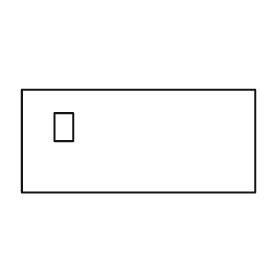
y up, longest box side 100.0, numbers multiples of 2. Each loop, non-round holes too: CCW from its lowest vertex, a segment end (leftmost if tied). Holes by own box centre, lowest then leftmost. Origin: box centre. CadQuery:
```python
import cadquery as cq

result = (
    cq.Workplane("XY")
    .moveTo(-50.0, -22.0)
    .lineTo(50.0, -22.0)
    .lineTo(50.0, 22.0)
    .lineTo(-50.0, 22.0)
    .close()
    .moveTo(-36.0, 0.0)
    .lineTo(-28.0, 0.0)
    .lineTo(-28.0, 12.0)
    .lineTo(-36.0, 12.0)
    .close()
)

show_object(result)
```